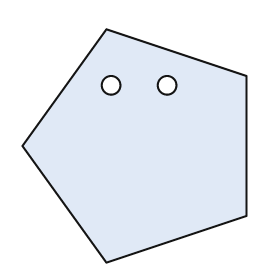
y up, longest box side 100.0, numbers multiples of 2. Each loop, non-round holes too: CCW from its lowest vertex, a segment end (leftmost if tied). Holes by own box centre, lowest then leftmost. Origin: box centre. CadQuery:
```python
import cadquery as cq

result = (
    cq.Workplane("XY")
    .moveTo(-12.0, -50.0)
    .lineTo(48.0, -30.0)
    .lineTo(48.0, 30.0)
    .lineTo(-12.0, 50.0)
    .lineTo(-48.0, 0.0)
    .close()
    .moveTo(-10.0, 26.0)
    .circle(4.0)
    .moveTo(14.0, 26.0)
    .circle(4.0)
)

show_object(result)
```